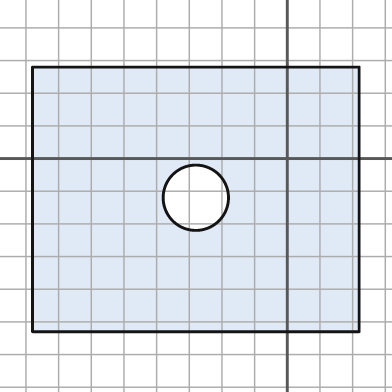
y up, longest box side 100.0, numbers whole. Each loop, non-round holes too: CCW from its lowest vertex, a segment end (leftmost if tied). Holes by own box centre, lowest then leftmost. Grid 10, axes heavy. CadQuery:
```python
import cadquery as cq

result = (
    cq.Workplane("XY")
    .moveTo(-78.0, -53.0)
    .lineTo(22.0, -53.0)
    .lineTo(22.0, 28.0)
    .lineTo(-78.0, 28.0)
    .close()
    .moveTo(-28.0, -12.0)
    .circle(10.0)
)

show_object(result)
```